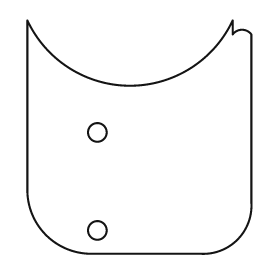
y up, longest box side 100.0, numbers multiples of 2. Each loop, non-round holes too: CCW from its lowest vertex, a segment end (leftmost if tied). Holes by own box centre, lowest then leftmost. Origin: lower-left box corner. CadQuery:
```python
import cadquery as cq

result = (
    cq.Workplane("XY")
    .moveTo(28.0, 0.0)
    .lineTo(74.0, 0.0)
    .threePointArc((90.0, 6.0), (96.0, 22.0))
    .lineTo(96.0, 94.0)
    .threePointArc((92.0, 96.0), (88.0, 94.0))
    .lineTo(88.0, 100.0)
    .threePointArc((44.0, 72.0), (0.0, 100.0))
    .lineTo(0.0, 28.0)
    .threePointArc((8.0, 8.0), (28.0, 0.0))
    .close()
    .moveTo(30.0, 10.0)
    .circle(4.0)
    .moveTo(30.0, 52.0)
    .circle(4.0)
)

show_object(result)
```